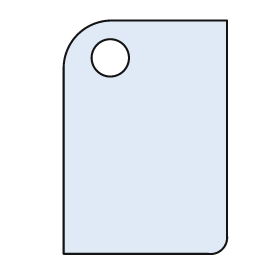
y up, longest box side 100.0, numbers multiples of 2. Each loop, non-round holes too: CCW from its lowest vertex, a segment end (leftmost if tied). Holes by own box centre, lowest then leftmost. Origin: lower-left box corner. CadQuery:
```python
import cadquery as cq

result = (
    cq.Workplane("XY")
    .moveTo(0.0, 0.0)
    .lineTo(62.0, 0.0)
    .threePointArc((68.0, 2.0), (70.0, 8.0))
    .lineTo(70.0, 100.0)
    .lineTo(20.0, 100.0)
    .threePointArc((6.0, 94.0), (0.0, 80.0))
    .close()
    .moveTo(20.0, 84.0)
    .circle(8.0)
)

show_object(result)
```